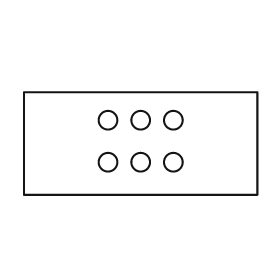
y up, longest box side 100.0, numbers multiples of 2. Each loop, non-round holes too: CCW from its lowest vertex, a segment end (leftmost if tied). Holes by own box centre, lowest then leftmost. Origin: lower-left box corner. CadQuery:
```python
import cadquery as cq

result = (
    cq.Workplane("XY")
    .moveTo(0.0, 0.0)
    .lineTo(100.0, 0.0)
    .lineTo(100.0, 44.0)
    .lineTo(0.0, 44.0)
    .close()
    .moveTo(36.0, 14.0)
    .circle(4.0)
    .moveTo(50.0, 14.0)
    .circle(4.0)
    .moveTo(64.0, 14.0)
    .circle(4.0)
    .moveTo(36.0, 32.0)
    .circle(4.0)
    .moveTo(50.0, 32.0)
    .circle(4.0)
    .moveTo(64.0, 32.0)
    .circle(4.0)
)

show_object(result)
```